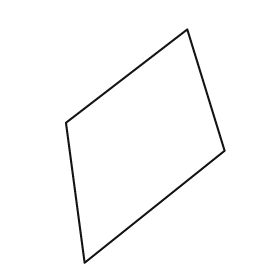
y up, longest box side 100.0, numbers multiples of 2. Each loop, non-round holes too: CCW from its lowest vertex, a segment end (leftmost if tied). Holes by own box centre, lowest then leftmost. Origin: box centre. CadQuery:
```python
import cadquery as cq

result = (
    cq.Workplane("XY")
    .moveTo(-26.0, -50.0)
    .lineTo(34.0, -2.0)
    .lineTo(18.0, 50.0)
    .lineTo(-34.0, 10.0)
    .close()
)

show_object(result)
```